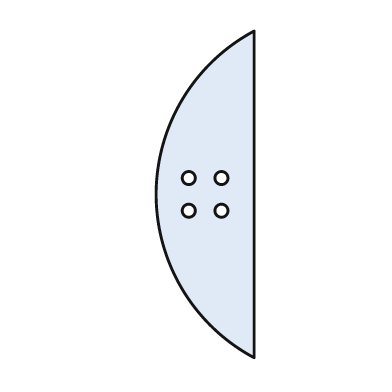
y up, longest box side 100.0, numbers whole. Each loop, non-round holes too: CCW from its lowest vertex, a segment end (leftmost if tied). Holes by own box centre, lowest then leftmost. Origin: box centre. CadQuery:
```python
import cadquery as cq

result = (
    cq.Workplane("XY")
    .moveTo(15.0, -50.0)
    .lineTo(15.0, 50.0)
    .threePointArc((-15.0, 0.0), (15.0, -50.0))
    .close()
    .moveTo(-5.0, -5.0)
    .circle(2.0)
    .moveTo(5.0, -5.0)
    .circle(2.0)
    .moveTo(-5.0, 5.0)
    .circle(2.0)
    .moveTo(5.0, 5.0)
    .circle(2.0)
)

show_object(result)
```